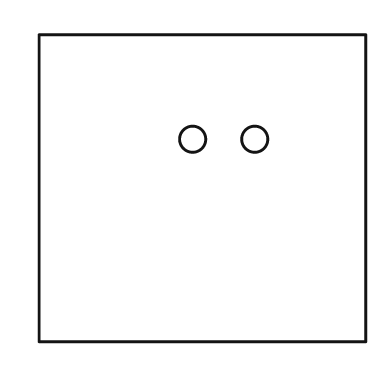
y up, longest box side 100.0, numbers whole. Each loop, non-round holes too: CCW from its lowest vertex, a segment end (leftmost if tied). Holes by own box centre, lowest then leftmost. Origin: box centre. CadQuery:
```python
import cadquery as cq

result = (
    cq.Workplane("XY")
    .moveTo(-50.0, -47.0)
    .lineTo(50.0, -47.0)
    .lineTo(50.0, 47.0)
    .lineTo(-50.0, 47.0)
    .close()
    .moveTo(-3.0, 15.0)
    .circle(4.0)
    .moveTo(16.0, 15.0)
    .circle(4.0)
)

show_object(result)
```